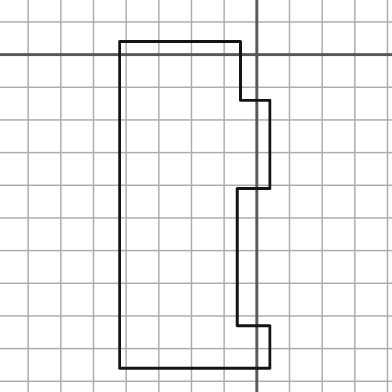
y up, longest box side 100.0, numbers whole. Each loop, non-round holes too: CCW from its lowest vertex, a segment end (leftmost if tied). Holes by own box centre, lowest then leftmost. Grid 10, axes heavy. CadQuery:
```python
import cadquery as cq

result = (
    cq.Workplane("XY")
    .moveTo(-42.0, -96.0)
    .lineTo(4.0, -96.0)
    .lineTo(4.0, -83.0)
    .lineTo(-6.0, -83.0)
    .lineTo(-6.0, -41.0)
    .lineTo(4.0, -41.0)
    .lineTo(4.0, -14.0)
    .lineTo(-5.0, -14.0)
    .lineTo(-5.0, 4.0)
    .lineTo(-42.0, 4.0)
    .close()
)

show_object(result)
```